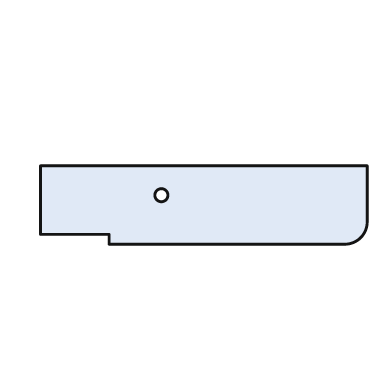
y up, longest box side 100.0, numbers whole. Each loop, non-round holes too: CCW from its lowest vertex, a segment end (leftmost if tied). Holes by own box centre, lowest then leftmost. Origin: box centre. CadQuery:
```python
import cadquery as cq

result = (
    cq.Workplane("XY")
    .moveTo(-29.0, -12.0)
    .lineTo(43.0, -12.0)
    .threePointArc((48.0, -10.0), (50.0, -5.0))
    .lineTo(50.0, 12.0)
    .lineTo(-50.0, 12.0)
    .lineTo(-50.0, -9.0)
    .lineTo(-29.0, -9.0)
    .close()
    .moveTo(-13.0, 3.0)
    .circle(2.0)
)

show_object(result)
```